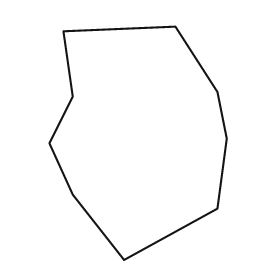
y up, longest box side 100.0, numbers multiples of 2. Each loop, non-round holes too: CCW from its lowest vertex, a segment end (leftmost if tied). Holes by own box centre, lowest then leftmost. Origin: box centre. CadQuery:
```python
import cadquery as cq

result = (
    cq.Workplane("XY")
    .moveTo(-6.0, -50.0)
    .lineTo(34.0, -28.0)
    .lineTo(38.0, 2.0)
    .lineTo(34.0, 22.0)
    .lineTo(16.0, 50.0)
    .lineTo(-32.0, 48.0)
    .lineTo(-28.0, 20.0)
    .lineTo(-38.0, 0.0)
    .lineTo(-28.0, -22.0)
    .close()
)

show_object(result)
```